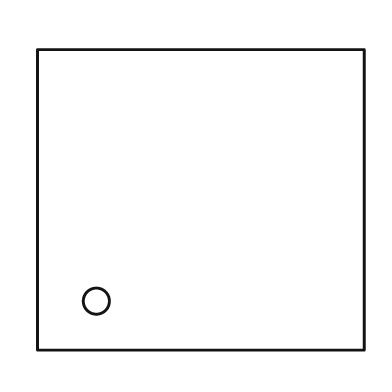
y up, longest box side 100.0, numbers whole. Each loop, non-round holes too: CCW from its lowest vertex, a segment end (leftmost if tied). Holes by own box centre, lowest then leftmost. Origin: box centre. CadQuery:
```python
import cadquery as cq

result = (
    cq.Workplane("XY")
    .moveTo(-50.0, -46.0)
    .lineTo(50.0, -46.0)
    .lineTo(50.0, 46.0)
    .lineTo(-50.0, 46.0)
    .close()
    .moveTo(-32.0, -31.0)
    .circle(4.0)
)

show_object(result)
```